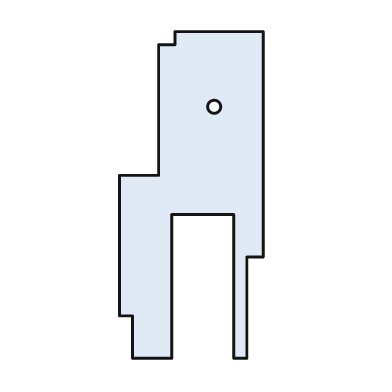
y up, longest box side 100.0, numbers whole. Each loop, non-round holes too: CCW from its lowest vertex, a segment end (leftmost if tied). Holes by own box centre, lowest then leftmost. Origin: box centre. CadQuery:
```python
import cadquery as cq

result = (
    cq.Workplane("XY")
    .moveTo(-18.0, -50.0)
    .lineTo(-6.0, -50.0)
    .lineTo(-6.0, -6.0)
    .lineTo(13.0, -6.0)
    .lineTo(13.0, -50.0)
    .lineTo(17.0, -50.0)
    .lineTo(17.0, -19.0)
    .lineTo(22.0, -19.0)
    .lineTo(22.0, 50.0)
    .lineTo(-5.0, 50.0)
    .lineTo(-5.0, 46.0)
    .lineTo(-10.0, 46.0)
    .lineTo(-10.0, 6.0)
    .lineTo(-22.0, 6.0)
    .lineTo(-22.0, -37.0)
    .lineTo(-18.0, -37.0)
    .close()
    .moveTo(7.0, 27.0)
    .circle(2.0)
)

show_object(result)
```